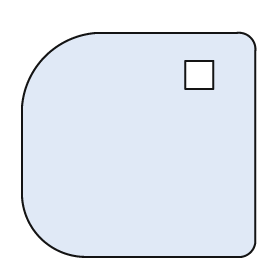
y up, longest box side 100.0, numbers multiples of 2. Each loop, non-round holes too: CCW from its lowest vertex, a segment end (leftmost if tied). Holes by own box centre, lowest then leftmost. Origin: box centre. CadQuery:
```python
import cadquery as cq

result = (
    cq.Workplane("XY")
    .moveTo(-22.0, -48.0)
    .lineTo(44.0, -48.0)
    .threePointArc((48.0, -46.0), (50.0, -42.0))
    .lineTo(50.0, 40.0)
    .threePointArc((48.0, 46.0), (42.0, 48.0))
    .lineTo(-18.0, 48.0)
    .threePointArc((-40.0, 38.0), (-50.0, 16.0))
    .lineTo(-50.0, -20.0)
    .threePointArc((-42.0, -40.0), (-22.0, -48.0))
    .close()
    .moveTo(20.0, 24.0)
    .lineTo(32.0, 24.0)
    .lineTo(32.0, 36.0)
    .lineTo(20.0, 36.0)
    .close()
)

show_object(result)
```